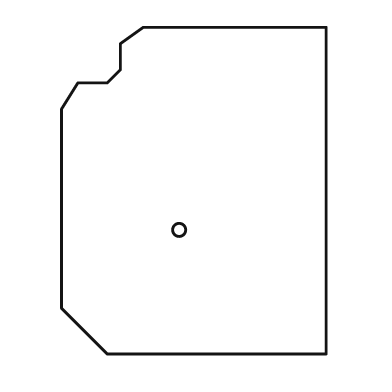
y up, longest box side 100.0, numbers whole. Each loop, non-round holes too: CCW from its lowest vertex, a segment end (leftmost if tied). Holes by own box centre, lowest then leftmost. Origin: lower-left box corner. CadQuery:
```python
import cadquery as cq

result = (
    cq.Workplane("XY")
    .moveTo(14.0, 0.0)
    .lineTo(81.0, 0.0)
    .lineTo(81.0, 100.0)
    .lineTo(25.0, 100.0)
    .lineTo(18.0, 95.0)
    .lineTo(18.0, 87.0)
    .lineTo(14.0, 83.0)
    .lineTo(5.0, 83.0)
    .lineTo(0.0, 75.0)
    .lineTo(0.0, 14.0)
    .close()
    .moveTo(36.0, 38.0)
    .circle(2.0)
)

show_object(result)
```